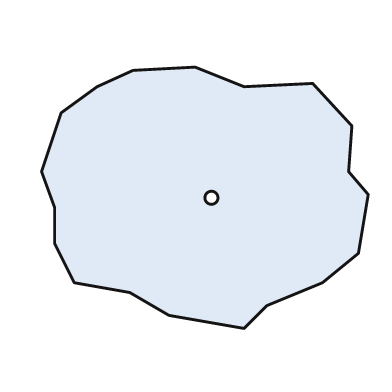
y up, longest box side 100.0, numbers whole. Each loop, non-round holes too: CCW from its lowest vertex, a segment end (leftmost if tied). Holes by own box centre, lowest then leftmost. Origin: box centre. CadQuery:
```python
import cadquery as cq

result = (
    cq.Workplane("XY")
    .moveTo(12.0, -40.0)
    .lineTo(19.0, -33.0)
    .lineTo(36.0, -26.0)
    .lineTo(47.0, -17.0)
    .lineTo(50.0, 1.0)
    .lineTo(44.0, 8.0)
    .lineTo(45.0, 22.0)
    .lineTo(33.0, 35.0)
    .lineTo(12.0, 34.0)
    .lineTo(-3.0, 40.0)
    .lineTo(-22.0, 39.0)
    .lineTo(-33.0, 34.0)
    .lineTo(-44.0, 26.0)
    .lineTo(-50.0, 8.0)
    .lineTo(-46.0, -3.0)
    .lineTo(-46.0, -14.0)
    .lineTo(-40.0, -26.0)
    .lineTo(-23.0, -29.0)
    .lineTo(-11.0, -36.0)
    .close()
    .moveTo(2.0, 0.0)
    .circle(2.0)
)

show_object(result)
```